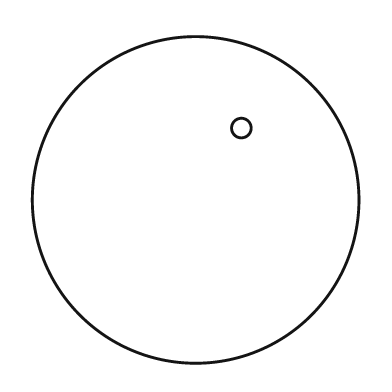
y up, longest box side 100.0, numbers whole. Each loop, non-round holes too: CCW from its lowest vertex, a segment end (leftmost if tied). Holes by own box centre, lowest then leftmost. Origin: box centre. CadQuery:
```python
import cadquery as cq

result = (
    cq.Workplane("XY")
    .moveTo(0.0, 0.0)
    .circle(50.0)
    .moveTo(14.0, 22.0)
    .circle(3.0)
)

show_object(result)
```